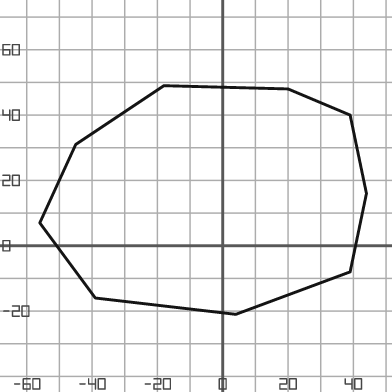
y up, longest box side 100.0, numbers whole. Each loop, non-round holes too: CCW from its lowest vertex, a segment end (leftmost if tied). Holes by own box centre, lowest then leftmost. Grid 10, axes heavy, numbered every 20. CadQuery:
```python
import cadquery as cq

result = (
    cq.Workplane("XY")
    .moveTo(4.0, -21.0)
    .lineTo(39.0, -8.0)
    .lineTo(44.0, 16.0)
    .lineTo(39.0, 40.0)
    .lineTo(20.0, 48.0)
    .lineTo(-18.0, 49.0)
    .lineTo(-45.0, 31.0)
    .lineTo(-56.0, 7.0)
    .lineTo(-39.0, -16.0)
    .close()
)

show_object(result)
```